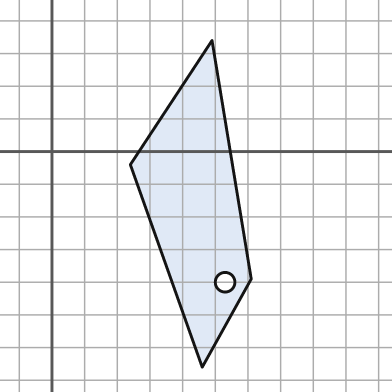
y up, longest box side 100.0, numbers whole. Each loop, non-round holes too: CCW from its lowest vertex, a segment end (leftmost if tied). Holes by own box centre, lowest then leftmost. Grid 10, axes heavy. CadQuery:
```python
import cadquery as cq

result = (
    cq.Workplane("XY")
    .moveTo(46.0, -66.0)
    .lineTo(61.0, -39.0)
    .lineTo(49.0, 34.0)
    .lineTo(24.0, -4.0)
    .close()
    .moveTo(53.0, -40.0)
    .circle(3.0)
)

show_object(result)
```